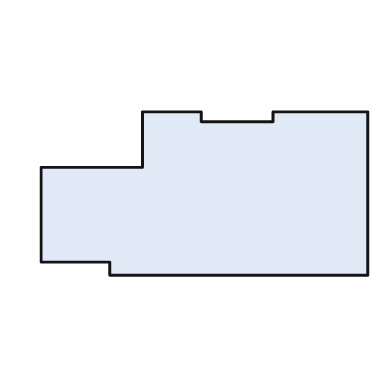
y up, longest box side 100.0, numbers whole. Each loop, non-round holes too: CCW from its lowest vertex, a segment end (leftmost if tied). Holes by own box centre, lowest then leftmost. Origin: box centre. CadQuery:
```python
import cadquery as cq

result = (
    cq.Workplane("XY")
    .moveTo(-29.0, -25.0)
    .lineTo(50.0, -25.0)
    .lineTo(50.0, 25.0)
    .lineTo(21.0, 25.0)
    .lineTo(21.0, 22.0)
    .lineTo(-1.0, 22.0)
    .lineTo(-1.0, 25.0)
    .lineTo(-19.0, 25.0)
    .lineTo(-19.0, 8.0)
    .lineTo(-50.0, 8.0)
    .lineTo(-50.0, -21.0)
    .lineTo(-29.0, -21.0)
    .close()
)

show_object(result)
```